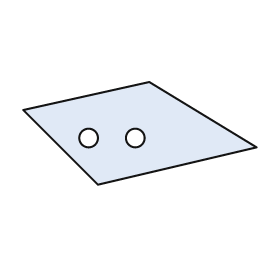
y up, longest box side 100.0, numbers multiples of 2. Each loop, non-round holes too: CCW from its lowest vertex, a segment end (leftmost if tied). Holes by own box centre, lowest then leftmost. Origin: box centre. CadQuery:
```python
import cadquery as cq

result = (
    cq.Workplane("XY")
    .moveTo(-18.0, -22.0)
    .lineTo(50.0, -6.0)
    .lineTo(4.0, 22.0)
    .lineTo(-50.0, 10.0)
    .close()
    .moveTo(-22.0, -2.0)
    .circle(4.0)
    .moveTo(-2.0, -2.0)
    .circle(4.0)
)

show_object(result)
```